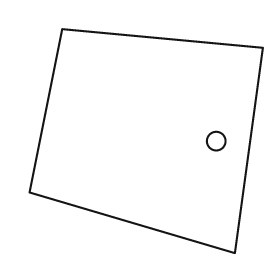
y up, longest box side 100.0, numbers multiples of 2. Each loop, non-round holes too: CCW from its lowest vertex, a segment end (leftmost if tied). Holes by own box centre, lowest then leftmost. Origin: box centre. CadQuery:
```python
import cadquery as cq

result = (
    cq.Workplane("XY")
    .moveTo(38.0, -48.0)
    .lineTo(50.0, 40.0)
    .lineTo(-36.0, 48.0)
    .lineTo(-50.0, -22.0)
    .close()
    .moveTo(30.0, 0.0)
    .circle(4.0)
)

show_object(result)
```